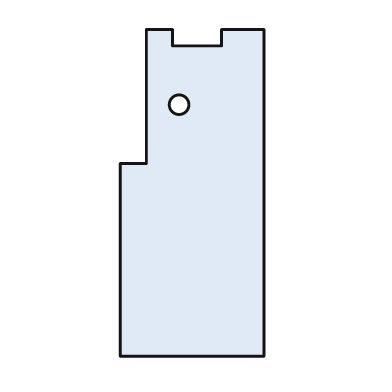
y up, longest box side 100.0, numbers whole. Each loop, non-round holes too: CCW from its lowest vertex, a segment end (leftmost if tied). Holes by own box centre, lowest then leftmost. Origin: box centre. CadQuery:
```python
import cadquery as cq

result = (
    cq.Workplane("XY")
    .moveTo(-22.0, -50.0)
    .lineTo(22.0, -50.0)
    .lineTo(22.0, 50.0)
    .lineTo(9.0, 50.0)
    .lineTo(9.0, 45.0)
    .lineTo(-6.0, 45.0)
    .lineTo(-6.0, 50.0)
    .lineTo(-14.0, 50.0)
    .lineTo(-14.0, 9.0)
    .lineTo(-22.0, 9.0)
    .close()
    .moveTo(-4.0, 27.0)
    .circle(3.0)
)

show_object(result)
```